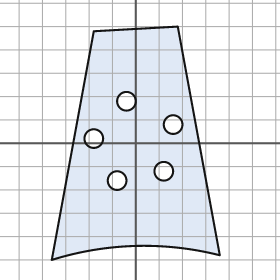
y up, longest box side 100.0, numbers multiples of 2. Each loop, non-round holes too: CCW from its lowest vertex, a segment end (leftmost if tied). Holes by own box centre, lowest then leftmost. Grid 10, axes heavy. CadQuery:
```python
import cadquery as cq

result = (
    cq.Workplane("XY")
    .moveTo(-36.0, -50.0)
    .threePointArc((0.0, -44.0), (36.0, -48.0))
    .lineTo(18.0, 50.0)
    .lineTo(-18.0, 48.0)
    .close()
    .moveTo(-8.0, -16.0)
    .circle(4.0)
    .moveTo(12.0, -12.0)
    .circle(4.0)
    .moveTo(-18.0, 2.0)
    .circle(4.0)
    .moveTo(16.0, 8.0)
    .circle(4.0)
    .moveTo(-4.0, 18.0)
    .circle(4.0)
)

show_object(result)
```